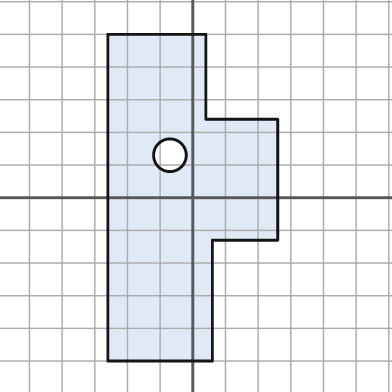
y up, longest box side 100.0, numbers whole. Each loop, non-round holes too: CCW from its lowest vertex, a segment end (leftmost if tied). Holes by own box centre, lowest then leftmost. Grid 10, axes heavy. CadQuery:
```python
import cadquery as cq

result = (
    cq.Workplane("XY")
    .moveTo(-26.0, -50.0)
    .lineTo(6.0, -50.0)
    .lineTo(6.0, -13.0)
    .lineTo(26.0, -13.0)
    .lineTo(26.0, 24.0)
    .lineTo(4.0, 24.0)
    .lineTo(4.0, 50.0)
    .lineTo(-26.0, 50.0)
    .close()
    .moveTo(-7.0, 13.0)
    .circle(5.0)
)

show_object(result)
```